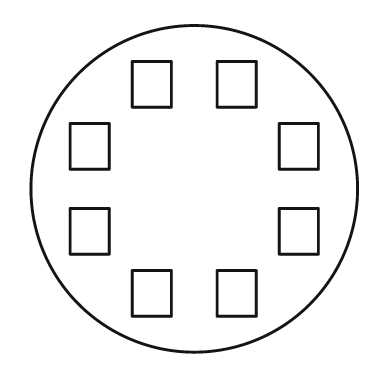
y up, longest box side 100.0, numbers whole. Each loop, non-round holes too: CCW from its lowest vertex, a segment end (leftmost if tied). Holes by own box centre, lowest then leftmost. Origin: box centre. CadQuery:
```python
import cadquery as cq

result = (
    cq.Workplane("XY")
    .moveTo(0.0, 0.0)
    .circle(50.0)
    .moveTo(-19.0, -39.0)
    .lineTo(-7.0, -39.0)
    .lineTo(-7.0, -25.0)
    .lineTo(-19.0, -25.0)
    .close()
    .moveTo(7.0, -39.0)
    .lineTo(19.0, -39.0)
    .lineTo(19.0, -25.0)
    .lineTo(7.0, -25.0)
    .close()
    .moveTo(-38.0, -20.0)
    .lineTo(-26.0, -20.0)
    .lineTo(-26.0, -6.0)
    .lineTo(-38.0, -6.0)
    .close()
    .moveTo(26.0, -20.0)
    .lineTo(38.0, -20.0)
    .lineTo(38.0, -6.0)
    .lineTo(26.0, -6.0)
    .close()
    .moveTo(-38.0, 6.0)
    .lineTo(-26.0, 6.0)
    .lineTo(-26.0, 20.0)
    .lineTo(-38.0, 20.0)
    .close()
    .moveTo(26.0, 6.0)
    .lineTo(38.0, 6.0)
    .lineTo(38.0, 20.0)
    .lineTo(26.0, 20.0)
    .close()
    .moveTo(-19.0, 25.0)
    .lineTo(-7.0, 25.0)
    .lineTo(-7.0, 39.0)
    .lineTo(-19.0, 39.0)
    .close()
    .moveTo(7.0, 25.0)
    .lineTo(19.0, 25.0)
    .lineTo(19.0, 39.0)
    .lineTo(7.0, 39.0)
    .close()
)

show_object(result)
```